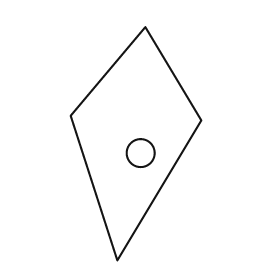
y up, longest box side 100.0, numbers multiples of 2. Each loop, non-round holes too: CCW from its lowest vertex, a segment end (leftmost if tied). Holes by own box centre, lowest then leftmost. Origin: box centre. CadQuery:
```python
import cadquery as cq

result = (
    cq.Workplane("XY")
    .moveTo(-8.0, -50.0)
    .lineTo(28.0, 10.0)
    .lineTo(4.0, 50.0)
    .lineTo(-28.0, 12.0)
    .close()
    .moveTo(2.0, -4.0)
    .circle(6.0)
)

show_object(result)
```